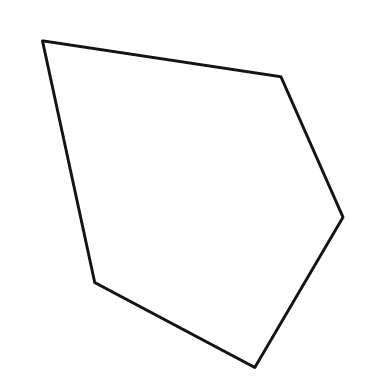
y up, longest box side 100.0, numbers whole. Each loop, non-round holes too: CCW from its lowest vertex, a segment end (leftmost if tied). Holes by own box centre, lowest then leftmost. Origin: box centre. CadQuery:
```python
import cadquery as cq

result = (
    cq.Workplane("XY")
    .moveTo(19.0, -50.0)
    .lineTo(46.0, -4.0)
    .lineTo(27.0, 39.0)
    .lineTo(-46.0, 50.0)
    .lineTo(-30.0, -24.0)
    .close()
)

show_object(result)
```